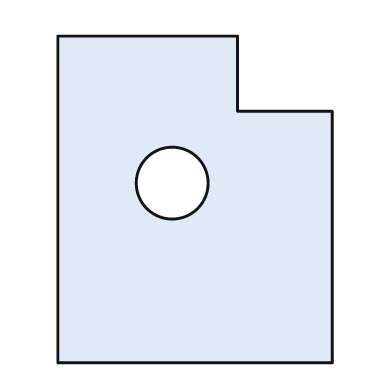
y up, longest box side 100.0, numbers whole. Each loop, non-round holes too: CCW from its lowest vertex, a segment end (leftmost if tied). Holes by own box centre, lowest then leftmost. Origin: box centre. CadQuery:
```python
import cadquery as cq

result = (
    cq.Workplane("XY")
    .moveTo(-42.0, -50.0)
    .lineTo(42.0, -50.0)
    .lineTo(42.0, 27.0)
    .lineTo(13.0, 27.0)
    .lineTo(13.0, 50.0)
    .lineTo(-42.0, 50.0)
    .close()
    .moveTo(-7.0, 5.0)
    .circle(11.0)
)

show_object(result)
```